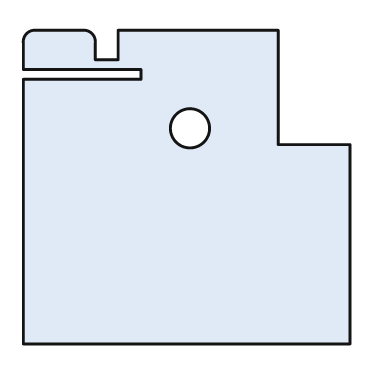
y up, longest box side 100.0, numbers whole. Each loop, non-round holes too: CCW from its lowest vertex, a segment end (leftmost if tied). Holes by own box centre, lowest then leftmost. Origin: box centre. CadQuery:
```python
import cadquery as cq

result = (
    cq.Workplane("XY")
    .moveTo(-50.0, -48.0)
    .lineTo(50.0, -48.0)
    .lineTo(50.0, 13.0)
    .lineTo(28.0, 13.0)
    .lineTo(28.0, 48.0)
    .lineTo(-21.0, 48.0)
    .lineTo(-21.0, 39.0)
    .lineTo(-28.0, 39.0)
    .lineTo(-28.0, 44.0)
    .threePointArc((-29.0, 47.0), (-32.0, 48.0))
    .lineTo(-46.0, 48.0)
    .threePointArc((-49.0, 47.0), (-50.0, 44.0))
    .lineTo(-50.0, 36.0)
    .lineTo(-14.0, 36.0)
    .lineTo(-14.0, 33.0)
    .lineTo(-50.0, 33.0)
    .close()
    .moveTo(1.0, 18.0)
    .circle(6.0)
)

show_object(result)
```